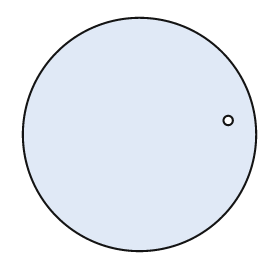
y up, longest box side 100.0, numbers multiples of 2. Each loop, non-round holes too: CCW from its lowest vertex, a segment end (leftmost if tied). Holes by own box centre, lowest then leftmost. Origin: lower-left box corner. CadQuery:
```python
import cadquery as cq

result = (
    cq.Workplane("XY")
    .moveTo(50.0, 50.0)
    .circle(50.0)
    .moveTo(88.0, 56.0)
    .circle(2.0)
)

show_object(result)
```